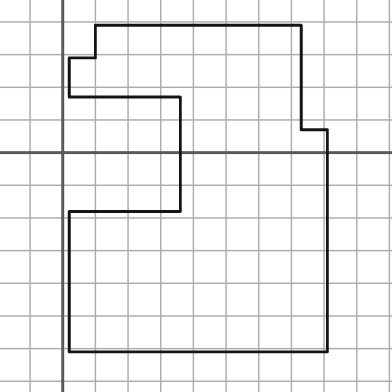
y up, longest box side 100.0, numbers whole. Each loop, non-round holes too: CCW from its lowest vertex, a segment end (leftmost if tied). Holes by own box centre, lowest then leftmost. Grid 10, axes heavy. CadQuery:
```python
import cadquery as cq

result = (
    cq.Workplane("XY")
    .moveTo(2.0, -61.0)
    .lineTo(81.0, -61.0)
    .lineTo(81.0, 7.0)
    .lineTo(73.0, 7.0)
    .lineTo(73.0, 39.0)
    .lineTo(10.0, 39.0)
    .lineTo(10.0, 29.0)
    .lineTo(2.0, 29.0)
    .lineTo(2.0, 17.0)
    .lineTo(36.0, 17.0)
    .lineTo(36.0, -18.0)
    .lineTo(2.0, -18.0)
    .close()
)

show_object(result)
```